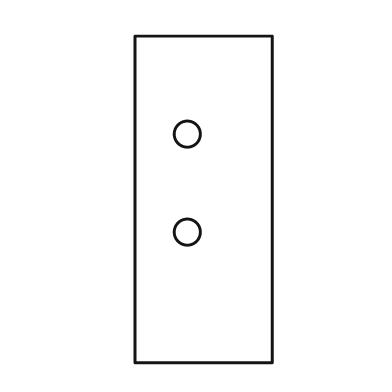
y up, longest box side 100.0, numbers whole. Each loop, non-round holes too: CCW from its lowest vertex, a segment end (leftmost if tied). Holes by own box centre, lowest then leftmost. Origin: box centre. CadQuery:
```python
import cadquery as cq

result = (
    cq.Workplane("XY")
    .moveTo(-21.0, -50.0)
    .lineTo(21.0, -50.0)
    .lineTo(21.0, 50.0)
    .lineTo(-21.0, 50.0)
    .close()
    .moveTo(-5.0, -10.0)
    .circle(4.0)
    .moveTo(-5.0, 20.0)
    .circle(4.0)
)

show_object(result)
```